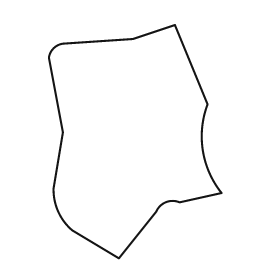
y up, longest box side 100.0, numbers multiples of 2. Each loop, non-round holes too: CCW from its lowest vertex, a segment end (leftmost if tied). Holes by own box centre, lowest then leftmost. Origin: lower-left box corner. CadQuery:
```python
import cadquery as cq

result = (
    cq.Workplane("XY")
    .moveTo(30.0, 0.0)
    .lineTo(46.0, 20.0)
    .threePointArc((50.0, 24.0), (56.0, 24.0))
    .lineTo(74.0, 28.0)
    .threePointArc((66.0, 46.0), (68.0, 66.0))
    .lineTo(54.0, 100.0)
    .lineTo(36.0, 94.0)
    .lineTo(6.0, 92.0)
    .threePointArc((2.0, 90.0), (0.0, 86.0))
    .lineTo(6.0, 54.0)
    .lineTo(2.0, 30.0)
    .threePointArc((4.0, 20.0), (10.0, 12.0))
    .close()
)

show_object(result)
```